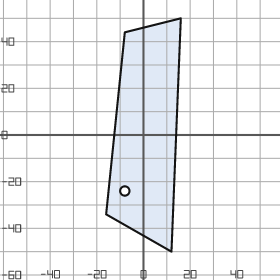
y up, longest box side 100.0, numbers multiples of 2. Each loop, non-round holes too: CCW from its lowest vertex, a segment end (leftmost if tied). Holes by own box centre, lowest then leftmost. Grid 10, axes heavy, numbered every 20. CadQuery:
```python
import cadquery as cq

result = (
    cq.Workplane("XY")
    .moveTo(12.0, -50.0)
    .lineTo(16.0, 50.0)
    .lineTo(-8.0, 44.0)
    .lineTo(-16.0, -34.0)
    .close()
    .moveTo(-8.0, -24.0)
    .circle(2.0)
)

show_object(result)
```